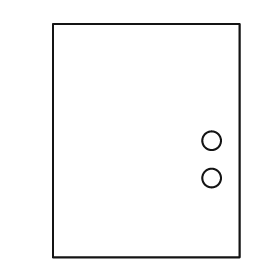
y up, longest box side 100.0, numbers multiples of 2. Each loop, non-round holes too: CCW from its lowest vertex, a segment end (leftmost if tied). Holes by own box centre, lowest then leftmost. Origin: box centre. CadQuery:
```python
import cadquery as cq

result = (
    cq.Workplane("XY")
    .moveTo(-40.0, -50.0)
    .lineTo(40.0, -50.0)
    .lineTo(40.0, 50.0)
    .lineTo(-40.0, 50.0)
    .close()
    .moveTo(28.0, -16.0)
    .circle(4.0)
    .moveTo(28.0, 0.0)
    .circle(4.0)
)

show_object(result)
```